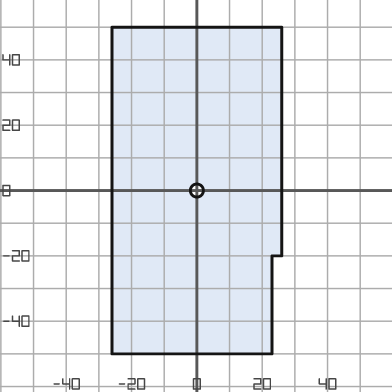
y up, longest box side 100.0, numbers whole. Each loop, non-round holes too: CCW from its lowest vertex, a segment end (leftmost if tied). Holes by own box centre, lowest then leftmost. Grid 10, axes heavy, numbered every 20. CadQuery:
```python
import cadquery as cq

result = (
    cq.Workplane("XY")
    .moveTo(-26.0, -50.0)
    .lineTo(23.0, -50.0)
    .lineTo(23.0, -20.0)
    .lineTo(26.0, -20.0)
    .lineTo(26.0, 50.0)
    .lineTo(-26.0, 50.0)
    .close()
    .moveTo(0.0, 0.0)
    .circle(2.0)
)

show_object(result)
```